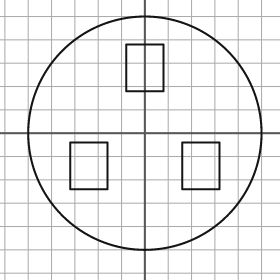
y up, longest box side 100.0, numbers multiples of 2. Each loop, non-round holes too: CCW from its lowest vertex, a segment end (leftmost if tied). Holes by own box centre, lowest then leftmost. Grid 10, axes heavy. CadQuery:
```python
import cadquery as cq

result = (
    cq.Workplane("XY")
    .moveTo(0.0, 0.0)
    .circle(50.0)
    .moveTo(-32.0, -24.0)
    .lineTo(-16.0, -24.0)
    .lineTo(-16.0, -4.0)
    .lineTo(-32.0, -4.0)
    .close()
    .moveTo(16.0, -24.0)
    .lineTo(32.0, -24.0)
    .lineTo(32.0, -4.0)
    .lineTo(16.0, -4.0)
    .close()
    .moveTo(-8.0, 18.0)
    .lineTo(8.0, 18.0)
    .lineTo(8.0, 38.0)
    .lineTo(-8.0, 38.0)
    .close()
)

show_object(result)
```